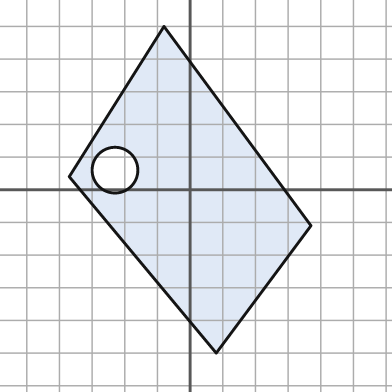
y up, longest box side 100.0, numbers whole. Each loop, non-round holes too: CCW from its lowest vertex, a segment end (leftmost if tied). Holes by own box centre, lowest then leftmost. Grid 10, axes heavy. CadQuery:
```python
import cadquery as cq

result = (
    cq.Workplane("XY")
    .moveTo(8.0, -50.0)
    .lineTo(37.0, -11.0)
    .lineTo(-8.0, 50.0)
    .lineTo(-37.0, 4.0)
    .close()
    .moveTo(-23.0, 6.0)
    .circle(7.0)
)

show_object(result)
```